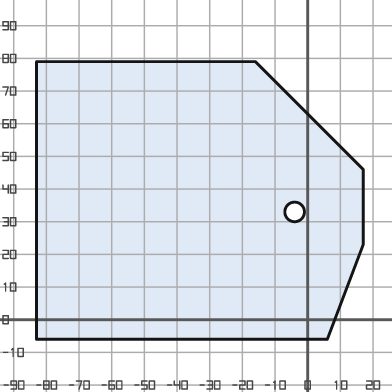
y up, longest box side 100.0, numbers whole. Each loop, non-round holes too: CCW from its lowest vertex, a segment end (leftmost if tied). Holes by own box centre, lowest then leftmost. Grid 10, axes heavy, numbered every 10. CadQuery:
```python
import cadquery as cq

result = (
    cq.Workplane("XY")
    .moveTo(-83.0, -6.0)
    .lineTo(6.0, -6.0)
    .lineTo(17.0, 23.0)
    .lineTo(17.0, 46.0)
    .lineTo(-16.0, 79.0)
    .lineTo(-83.0, 79.0)
    .close()
    .moveTo(-4.0, 33.0)
    .circle(3.0)
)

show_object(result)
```